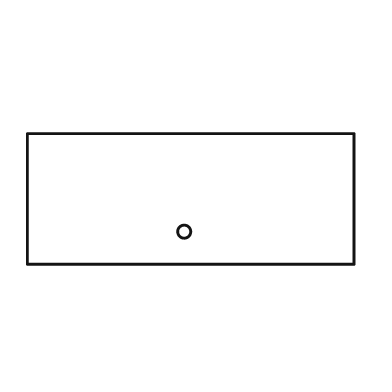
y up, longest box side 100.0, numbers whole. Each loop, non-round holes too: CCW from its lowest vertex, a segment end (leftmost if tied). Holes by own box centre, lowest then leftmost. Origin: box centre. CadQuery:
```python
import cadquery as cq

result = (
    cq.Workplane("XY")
    .moveTo(-50.0, -20.0)
    .lineTo(50.0, -20.0)
    .lineTo(50.0, 20.0)
    .lineTo(-50.0, 20.0)
    .close()
    .moveTo(-2.0, -10.0)
    .circle(2.0)
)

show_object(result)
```